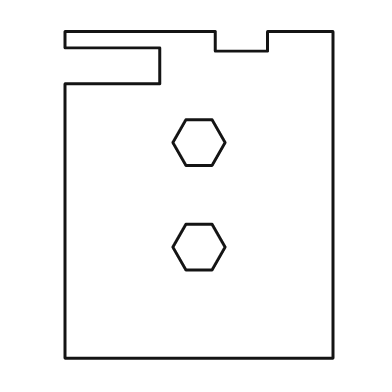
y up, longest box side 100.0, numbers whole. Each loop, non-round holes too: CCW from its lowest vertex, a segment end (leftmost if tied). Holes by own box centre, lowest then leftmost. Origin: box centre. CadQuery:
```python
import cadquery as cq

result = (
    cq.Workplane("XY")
    .moveTo(-41.0, -50.0)
    .lineTo(41.0, -50.0)
    .lineTo(41.0, 50.0)
    .lineTo(21.0, 50.0)
    .lineTo(21.0, 44.0)
    .lineTo(5.0, 44.0)
    .lineTo(5.0, 50.0)
    .lineTo(-41.0, 50.0)
    .lineTo(-41.0, 45.0)
    .lineTo(-12.0, 45.0)
    .lineTo(-12.0, 34.0)
    .lineTo(-41.0, 34.0)
    .close()
    .moveTo(-4.0, -23.0)
    .lineTo(4.0, -23.0)
    .lineTo(8.0, -16.0)
    .lineTo(4.0, -9.0)
    .lineTo(-4.0, -9.0)
    .lineTo(-8.0, -16.0)
    .close()
    .moveTo(-4.0, 9.0)
    .lineTo(4.0, 9.0)
    .lineTo(8.0, 16.0)
    .lineTo(4.0, 23.0)
    .lineTo(-4.0, 23.0)
    .lineTo(-8.0, 16.0)
    .close()
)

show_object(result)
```